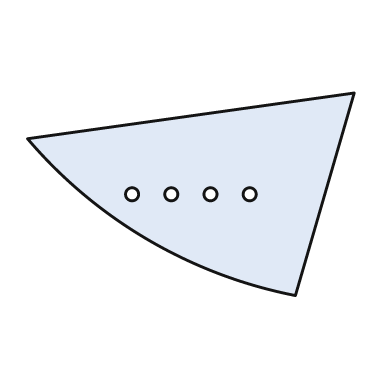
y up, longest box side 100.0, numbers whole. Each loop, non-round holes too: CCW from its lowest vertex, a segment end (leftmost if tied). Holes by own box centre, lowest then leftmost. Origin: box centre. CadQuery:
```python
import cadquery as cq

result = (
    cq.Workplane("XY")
    .moveTo(32.0, -31.0)
    .lineTo(50.0, 31.0)
    .lineTo(-50.0, 17.0)
    .threePointArc((-13.0, -14.0), (32.0, -31.0))
    .close()
    .moveTo(-18.0, 0.0)
    .circle(2.0)
    .moveTo(-6.0, 0.0)
    .circle(2.0)
    .moveTo(6.0, 0.0)
    .circle(2.0)
    .moveTo(18.0, 0.0)
    .circle(2.0)
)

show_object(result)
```